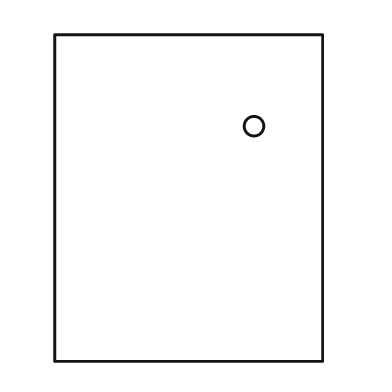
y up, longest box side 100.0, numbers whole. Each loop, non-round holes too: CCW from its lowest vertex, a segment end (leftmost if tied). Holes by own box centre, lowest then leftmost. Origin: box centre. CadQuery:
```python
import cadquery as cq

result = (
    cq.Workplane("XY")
    .moveTo(-41.0, -50.0)
    .lineTo(41.0, -50.0)
    .lineTo(41.0, 50.0)
    .lineTo(-41.0, 50.0)
    .close()
    .moveTo(20.0, 22.0)
    .circle(3.0)
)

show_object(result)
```